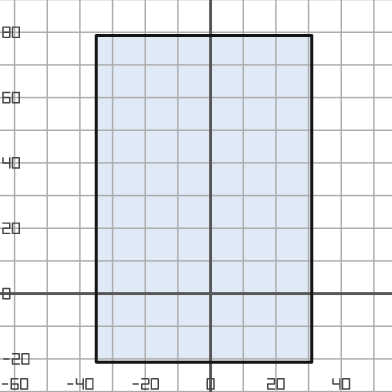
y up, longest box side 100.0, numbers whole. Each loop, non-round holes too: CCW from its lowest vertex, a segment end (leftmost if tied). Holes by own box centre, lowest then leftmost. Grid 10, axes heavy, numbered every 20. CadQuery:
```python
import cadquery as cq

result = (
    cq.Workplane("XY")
    .moveTo(-35.0, -21.0)
    .lineTo(31.0, -21.0)
    .lineTo(31.0, 79.0)
    .lineTo(-35.0, 79.0)
    .close()
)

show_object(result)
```